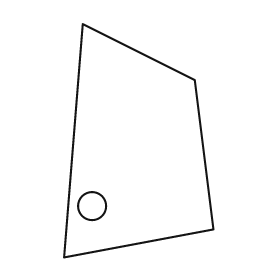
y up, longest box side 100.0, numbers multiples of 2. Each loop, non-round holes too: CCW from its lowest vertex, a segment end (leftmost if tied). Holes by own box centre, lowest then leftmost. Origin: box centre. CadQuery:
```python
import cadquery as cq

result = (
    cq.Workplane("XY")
    .moveTo(-32.0, -50.0)
    .lineTo(32.0, -38.0)
    .lineTo(24.0, 26.0)
    .lineTo(-24.0, 50.0)
    .close()
    .moveTo(-20.0, -28.0)
    .circle(6.0)
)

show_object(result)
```